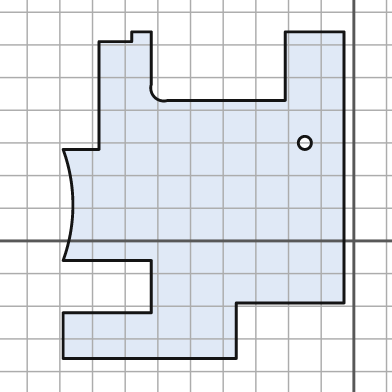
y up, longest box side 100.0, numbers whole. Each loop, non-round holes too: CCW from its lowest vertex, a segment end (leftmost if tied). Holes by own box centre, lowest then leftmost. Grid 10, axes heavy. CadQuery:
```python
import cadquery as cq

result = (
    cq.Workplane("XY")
    .moveTo(-89.0, -36.0)
    .lineTo(-36.0, -36.0)
    .lineTo(-36.0, -19.0)
    .lineTo(-3.0, -19.0)
    .lineTo(-3.0, 64.0)
    .lineTo(-21.0, 64.0)
    .lineTo(-21.0, 43.0)
    .lineTo(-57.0, 43.0)
    .threePointArc((-61.0, 44.0), (-62.0, 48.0))
    .lineTo(-62.0, 64.0)
    .lineTo(-68.0, 64.0)
    .lineTo(-68.0, 61.0)
    .lineTo(-78.0, 61.0)
    .lineTo(-78.0, 28.0)
    .lineTo(-89.0, 28.0)
    .threePointArc((-86.0, 11.0), (-89.0, -6.0))
    .lineTo(-62.0, -6.0)
    .lineTo(-62.0, -22.0)
    .lineTo(-89.0, -22.0)
    .close()
    .moveTo(-15.0, 30.0)
    .circle(2.0)
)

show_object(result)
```